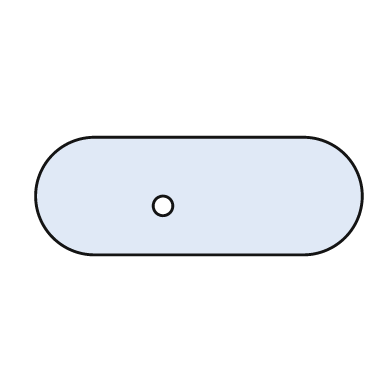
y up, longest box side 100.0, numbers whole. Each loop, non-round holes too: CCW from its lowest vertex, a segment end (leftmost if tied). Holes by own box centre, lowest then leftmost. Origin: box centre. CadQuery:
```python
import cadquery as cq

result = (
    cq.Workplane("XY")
    .moveTo(-32.0, -18.0)
    .lineTo(32.0, -18.0)
    .threePointArc((50.0, 0.0), (32.0, 18.0))
    .lineTo(-32.0, 18.0)
    .threePointArc((-50.0, 0.0), (-32.0, -18.0))
    .close()
    .moveTo(-11.0, -3.0)
    .circle(3.0)
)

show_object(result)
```